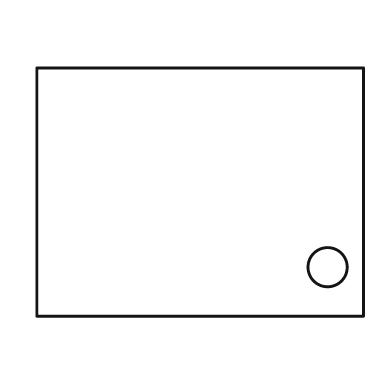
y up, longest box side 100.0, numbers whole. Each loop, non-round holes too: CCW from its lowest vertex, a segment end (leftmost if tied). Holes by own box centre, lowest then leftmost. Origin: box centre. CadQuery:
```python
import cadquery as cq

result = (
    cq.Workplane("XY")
    .moveTo(-50.0, -38.0)
    .lineTo(50.0, -38.0)
    .lineTo(50.0, 38.0)
    .lineTo(-50.0, 38.0)
    .close()
    .moveTo(39.0, -23.0)
    .circle(6.0)
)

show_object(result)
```